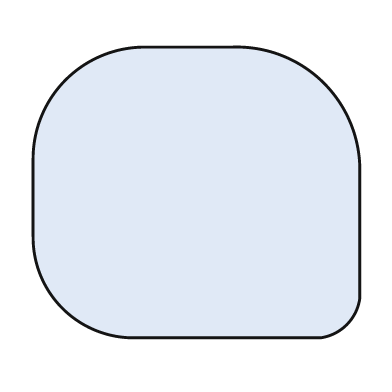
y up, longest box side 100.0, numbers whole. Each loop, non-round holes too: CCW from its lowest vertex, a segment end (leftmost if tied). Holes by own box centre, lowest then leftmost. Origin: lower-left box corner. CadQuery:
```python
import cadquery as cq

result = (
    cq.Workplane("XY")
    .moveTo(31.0, 0.0)
    .lineTo(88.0, 0.0)
    .threePointArc((96.0, 4.0), (100.0, 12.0))
    .lineTo(100.0, 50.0)
    .threePointArc((89.0, 78.0), (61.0, 89.0))
    .lineTo(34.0, 89.0)
    .threePointArc((10.0, 79.0), (0.0, 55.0))
    .lineTo(0.0, 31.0)
    .threePointArc((9.0, 9.0), (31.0, 0.0))
    .close()
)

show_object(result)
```